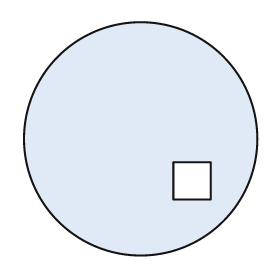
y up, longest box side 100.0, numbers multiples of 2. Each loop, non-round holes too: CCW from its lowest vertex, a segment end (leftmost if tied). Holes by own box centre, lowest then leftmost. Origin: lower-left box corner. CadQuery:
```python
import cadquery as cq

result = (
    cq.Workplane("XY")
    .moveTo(50.0, 50.0)
    .circle(50.0)
    .moveTo(64.0, 24.0)
    .lineTo(80.0, 24.0)
    .lineTo(80.0, 40.0)
    .lineTo(64.0, 40.0)
    .close()
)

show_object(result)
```